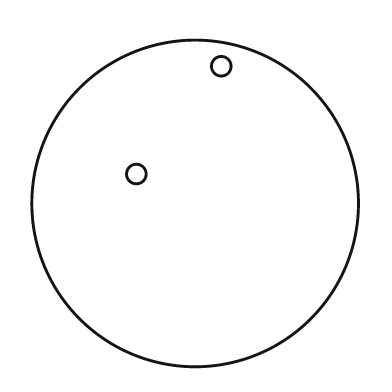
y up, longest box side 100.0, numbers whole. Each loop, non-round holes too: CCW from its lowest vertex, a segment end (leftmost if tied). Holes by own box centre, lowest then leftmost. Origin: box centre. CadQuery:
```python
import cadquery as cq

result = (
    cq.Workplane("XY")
    .moveTo(0.0, 0.0)
    .circle(50.0)
    .moveTo(-18.0, 9.0)
    .circle(3.0)
    .moveTo(8.0, 42.0)
    .circle(3.0)
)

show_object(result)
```